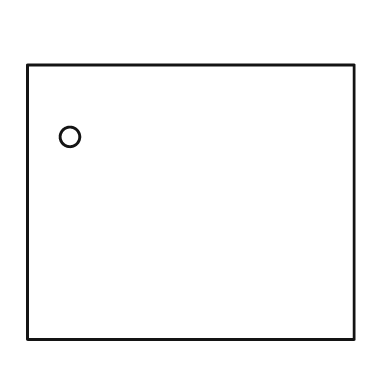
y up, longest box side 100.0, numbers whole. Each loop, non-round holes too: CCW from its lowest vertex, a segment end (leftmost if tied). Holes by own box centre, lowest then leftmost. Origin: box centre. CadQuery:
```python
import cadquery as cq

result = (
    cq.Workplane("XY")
    .moveTo(-50.0, -42.0)
    .lineTo(50.0, -42.0)
    .lineTo(50.0, 42.0)
    .lineTo(-50.0, 42.0)
    .close()
    .moveTo(-37.0, 20.0)
    .circle(3.0)
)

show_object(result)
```